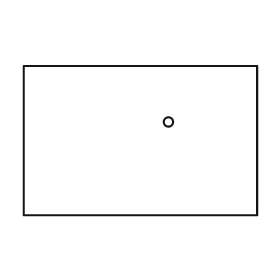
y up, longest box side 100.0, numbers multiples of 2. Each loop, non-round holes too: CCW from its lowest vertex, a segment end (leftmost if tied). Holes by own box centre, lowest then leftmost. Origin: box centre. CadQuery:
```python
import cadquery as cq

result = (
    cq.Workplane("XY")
    .moveTo(-50.0, -32.0)
    .lineTo(50.0, -32.0)
    .lineTo(50.0, 32.0)
    .lineTo(-50.0, 32.0)
    .close()
    .moveTo(12.0, 8.0)
    .circle(2.0)
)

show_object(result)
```